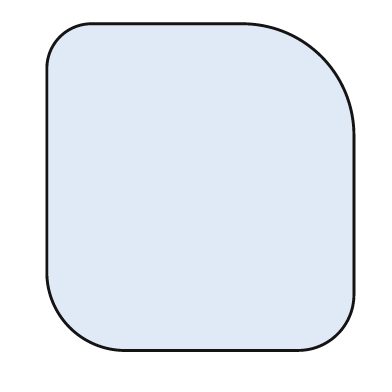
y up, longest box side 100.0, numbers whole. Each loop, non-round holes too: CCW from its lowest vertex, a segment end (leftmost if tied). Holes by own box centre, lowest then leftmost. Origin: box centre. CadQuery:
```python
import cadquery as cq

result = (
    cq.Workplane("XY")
    .moveTo(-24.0, -50.0)
    .lineTo(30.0, -50.0)
    .threePointArc((42.0, -45.0), (47.0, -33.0))
    .lineTo(47.0, 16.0)
    .threePointArc((37.0, 40.0), (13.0, 50.0))
    .lineTo(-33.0, 50.0)
    .threePointArc((-43.0, 46.0), (-47.0, 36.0))
    .lineTo(-47.0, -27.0)
    .threePointArc((-40.0, -43.0), (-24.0, -50.0))
    .close()
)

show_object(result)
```